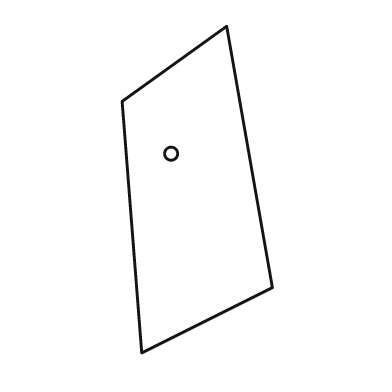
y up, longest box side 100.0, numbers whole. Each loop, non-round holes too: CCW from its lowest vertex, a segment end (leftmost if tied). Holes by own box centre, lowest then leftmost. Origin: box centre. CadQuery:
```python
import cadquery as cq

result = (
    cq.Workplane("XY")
    .moveTo(-17.0, -50.0)
    .lineTo(23.0, -30.0)
    .lineTo(9.0, 50.0)
    .lineTo(-23.0, 27.0)
    .close()
    .moveTo(-8.0, 11.0)
    .circle(2.0)
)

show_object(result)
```